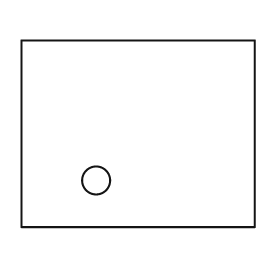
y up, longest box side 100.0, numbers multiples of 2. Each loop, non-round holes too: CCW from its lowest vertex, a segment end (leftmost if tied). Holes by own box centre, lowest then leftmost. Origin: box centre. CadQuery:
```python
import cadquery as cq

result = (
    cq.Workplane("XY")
    .moveTo(-50.0, -40.0)
    .lineTo(50.0, -40.0)
    .lineTo(50.0, 40.0)
    .lineTo(-50.0, 40.0)
    .close()
    .moveTo(-18.0, -20.0)
    .circle(6.0)
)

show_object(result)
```